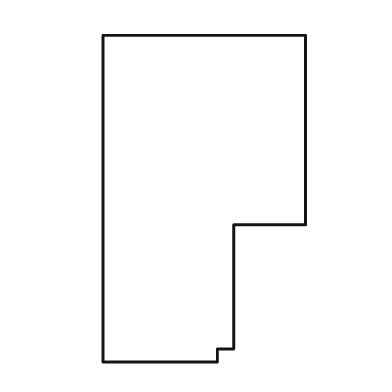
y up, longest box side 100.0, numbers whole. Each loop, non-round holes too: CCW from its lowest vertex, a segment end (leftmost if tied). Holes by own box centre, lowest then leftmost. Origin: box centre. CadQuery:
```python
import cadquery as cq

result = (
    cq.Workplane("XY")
    .moveTo(-31.0, -50.0)
    .lineTo(4.0, -50.0)
    .lineTo(4.0, -46.0)
    .lineTo(9.0, -46.0)
    .lineTo(9.0, -8.0)
    .lineTo(31.0, -8.0)
    .lineTo(31.0, 50.0)
    .lineTo(-31.0, 50.0)
    .close()
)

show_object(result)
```